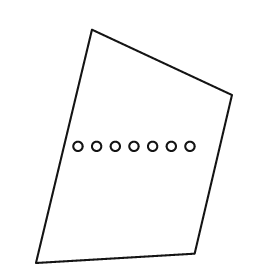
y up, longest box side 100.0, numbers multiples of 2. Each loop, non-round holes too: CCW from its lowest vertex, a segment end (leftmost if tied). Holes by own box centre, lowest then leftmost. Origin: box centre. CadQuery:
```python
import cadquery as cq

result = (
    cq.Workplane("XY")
    .moveTo(-42.0, -50.0)
    .lineTo(26.0, -46.0)
    .lineTo(42.0, 22.0)
    .lineTo(-18.0, 50.0)
    .close()
    .moveTo(-24.0, 0.0)
    .circle(2.0)
    .moveTo(-16.0, 0.0)
    .circle(2.0)
    .moveTo(-8.0, 0.0)
    .circle(2.0)
    .moveTo(0.0, 0.0)
    .circle(2.0)
    .moveTo(8.0, 0.0)
    .circle(2.0)
    .moveTo(16.0, 0.0)
    .circle(2.0)
    .moveTo(24.0, 0.0)
    .circle(2.0)
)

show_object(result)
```